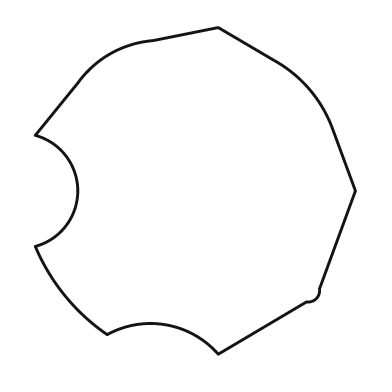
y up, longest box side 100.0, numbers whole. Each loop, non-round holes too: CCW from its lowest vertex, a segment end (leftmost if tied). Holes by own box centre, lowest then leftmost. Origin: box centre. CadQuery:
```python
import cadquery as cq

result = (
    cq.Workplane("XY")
    .moveTo(7.0, -50.0)
    .lineTo(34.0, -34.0)
    .threePointArc((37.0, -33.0), (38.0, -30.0))
    .lineTo(49.0, 0.0)
    .lineTo(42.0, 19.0)
    .threePointArc((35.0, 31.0), (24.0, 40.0))
    .lineTo(7.0, 50.0)
    .lineTo(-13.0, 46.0)
    .threePointArc((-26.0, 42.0), (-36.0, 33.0))
    .lineTo(-49.0, 17.0)
    .threePointArc((-36.0, 0.0), (-49.0, -17.0))
    .threePointArc((-40.0, -32.0), (-27.0, -44.0))
    .threePointArc((-9.0, -41.0), (7.0, -50.0))
    .close()
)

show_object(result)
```